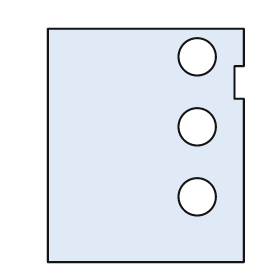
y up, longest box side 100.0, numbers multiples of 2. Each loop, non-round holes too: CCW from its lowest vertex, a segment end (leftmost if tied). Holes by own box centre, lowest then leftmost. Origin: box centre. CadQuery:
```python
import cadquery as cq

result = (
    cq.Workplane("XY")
    .moveTo(-42.0, -50.0)
    .lineTo(42.0, -50.0)
    .lineTo(42.0, 20.0)
    .lineTo(38.0, 20.0)
    .lineTo(38.0, 34.0)
    .lineTo(42.0, 34.0)
    .lineTo(42.0, 50.0)
    .lineTo(-42.0, 50.0)
    .close()
    .moveTo(22.0, -22.0)
    .circle(8.0)
    .moveTo(22.0, 8.0)
    .circle(8.0)
    .moveTo(22.0, 38.0)
    .circle(8.0)
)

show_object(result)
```